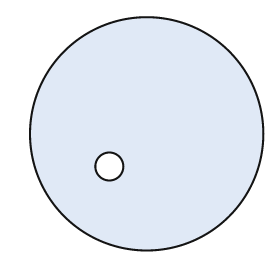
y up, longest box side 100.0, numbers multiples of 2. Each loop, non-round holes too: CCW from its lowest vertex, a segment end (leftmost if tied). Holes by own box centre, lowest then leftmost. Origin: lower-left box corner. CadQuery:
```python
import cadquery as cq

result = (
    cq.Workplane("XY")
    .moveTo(50.0, 50.0)
    .circle(50.0)
    .moveTo(34.0, 36.0)
    .circle(6.0)
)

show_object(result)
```